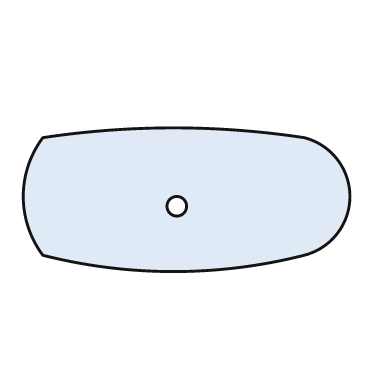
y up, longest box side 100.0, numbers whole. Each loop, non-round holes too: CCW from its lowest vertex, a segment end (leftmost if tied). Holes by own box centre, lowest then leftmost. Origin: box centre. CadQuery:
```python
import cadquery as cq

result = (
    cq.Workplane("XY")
    .moveTo(-44.0, -17.0)
    .threePointArc((-4.0, -22.0), (36.0, -17.0))
    .threePointArc((50.0, 1.0), (36.0, 19.0))
    .threePointArc((-4.0, 22.0), (-44.0, 19.0))
    .threePointArc((-50.0, 1.0), (-44.0, -17.0))
    .close()
    .moveTo(-3.0, -2.0)
    .circle(3.0)
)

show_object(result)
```